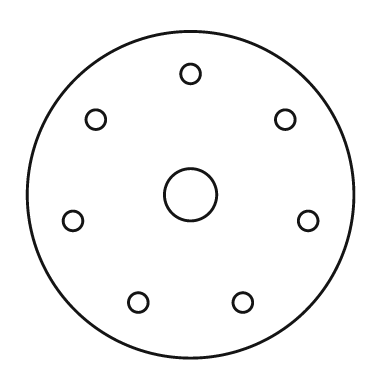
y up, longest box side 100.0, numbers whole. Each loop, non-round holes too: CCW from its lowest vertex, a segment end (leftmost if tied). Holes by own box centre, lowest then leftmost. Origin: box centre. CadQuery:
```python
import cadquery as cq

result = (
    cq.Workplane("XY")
    .moveTo(0.0, 0.0)
    .circle(50.0)
    .moveTo(-16.0, -33.0)
    .circle(3.0)
    .moveTo(16.0, -33.0)
    .circle(3.0)
    .moveTo(-36.0, -8.0)
    .circle(3.0)
    .moveTo(36.0, -8.0)
    .circle(3.0)
    .moveTo(0.0, 0.0)
    .circle(8.0)
    .moveTo(-29.0, 23.0)
    .circle(3.0)
    .moveTo(29.0, 23.0)
    .circle(3.0)
    .moveTo(0.0, 37.0)
    .circle(3.0)
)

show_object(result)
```